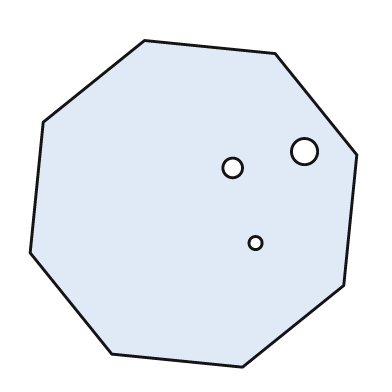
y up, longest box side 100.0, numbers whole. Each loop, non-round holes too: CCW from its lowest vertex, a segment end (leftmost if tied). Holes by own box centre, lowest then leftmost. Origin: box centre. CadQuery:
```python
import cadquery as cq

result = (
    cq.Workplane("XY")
    .moveTo(15.0, -50.0)
    .lineTo(46.0, -25.0)
    .lineTo(50.0, 15.0)
    .lineTo(25.0, 46.0)
    .lineTo(-15.0, 50.0)
    .lineTo(-46.0, 25.0)
    .lineTo(-50.0, -15.0)
    .lineTo(-25.0, -46.0)
    .close()
    .moveTo(19.0, -12.0)
    .circle(2.0)
    .moveTo(12.0, 11.0)
    .circle(3.0)
    .moveTo(34.0, 16.0)
    .circle(4.0)
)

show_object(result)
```